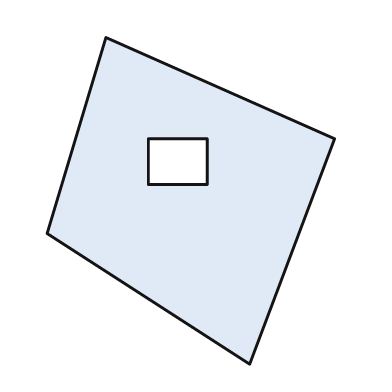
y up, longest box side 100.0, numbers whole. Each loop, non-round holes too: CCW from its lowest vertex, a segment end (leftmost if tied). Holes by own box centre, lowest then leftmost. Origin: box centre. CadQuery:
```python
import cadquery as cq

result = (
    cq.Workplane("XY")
    .moveTo(18.0, -50.0)
    .lineTo(44.0, 19.0)
    .lineTo(-26.0, 50.0)
    .lineTo(-44.0, -10.0)
    .close()
    .moveTo(-13.0, 5.0)
    .lineTo(5.0, 5.0)
    .lineTo(5.0, 19.0)
    .lineTo(-13.0, 19.0)
    .close()
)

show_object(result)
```